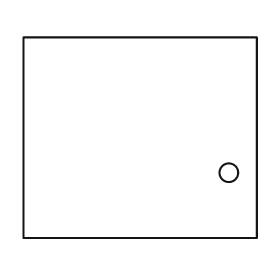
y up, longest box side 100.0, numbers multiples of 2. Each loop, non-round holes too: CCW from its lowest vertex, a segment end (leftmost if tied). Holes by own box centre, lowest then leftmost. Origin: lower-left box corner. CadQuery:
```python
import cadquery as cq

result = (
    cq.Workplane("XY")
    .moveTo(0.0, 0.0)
    .lineTo(100.0, 0.0)
    .lineTo(100.0, 86.0)
    .lineTo(0.0, 86.0)
    .close()
    .moveTo(88.0, 28.0)
    .circle(4.0)
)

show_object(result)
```